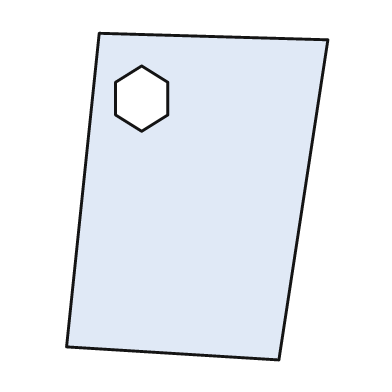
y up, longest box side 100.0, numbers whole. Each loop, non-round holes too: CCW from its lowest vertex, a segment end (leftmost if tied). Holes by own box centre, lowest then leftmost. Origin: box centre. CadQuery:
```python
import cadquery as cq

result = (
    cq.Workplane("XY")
    .moveTo(25.0, -50.0)
    .lineTo(40.0, 48.0)
    .lineTo(-30.0, 50.0)
    .lineTo(-40.0, -46.0)
    .close()
    .moveTo(-17.0, 20.0)
    .lineTo(-9.0, 25.0)
    .lineTo(-9.0, 35.0)
    .lineTo(-17.0, 40.0)
    .lineTo(-25.0, 35.0)
    .lineTo(-25.0, 25.0)
    .close()
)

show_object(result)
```